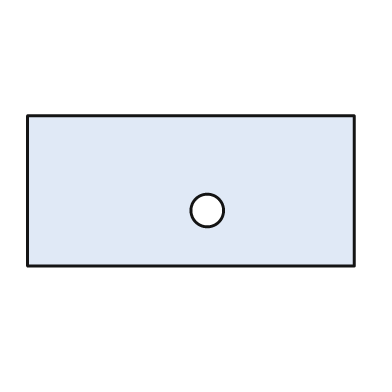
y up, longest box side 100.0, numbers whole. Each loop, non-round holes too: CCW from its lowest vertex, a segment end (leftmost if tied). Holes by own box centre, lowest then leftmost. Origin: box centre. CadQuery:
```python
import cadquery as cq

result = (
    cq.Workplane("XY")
    .moveTo(-50.0, -23.0)
    .lineTo(50.0, -23.0)
    .lineTo(50.0, 23.0)
    .lineTo(-50.0, 23.0)
    .close()
    .moveTo(5.0, -6.0)
    .circle(5.0)
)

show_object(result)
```